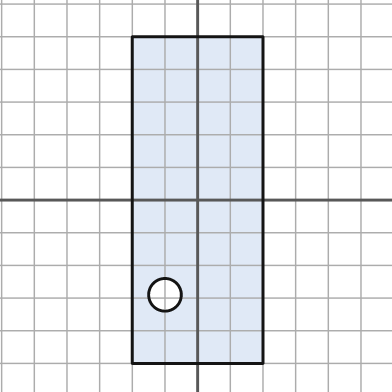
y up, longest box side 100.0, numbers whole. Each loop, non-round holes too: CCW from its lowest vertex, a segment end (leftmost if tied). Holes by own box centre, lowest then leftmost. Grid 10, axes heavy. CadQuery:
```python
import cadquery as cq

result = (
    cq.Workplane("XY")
    .moveTo(-20.0, -50.0)
    .lineTo(20.0, -50.0)
    .lineTo(20.0, 50.0)
    .lineTo(-20.0, 50.0)
    .close()
    .moveTo(-10.0, -29.0)
    .circle(5.0)
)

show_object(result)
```